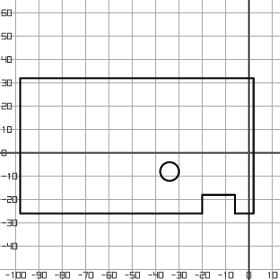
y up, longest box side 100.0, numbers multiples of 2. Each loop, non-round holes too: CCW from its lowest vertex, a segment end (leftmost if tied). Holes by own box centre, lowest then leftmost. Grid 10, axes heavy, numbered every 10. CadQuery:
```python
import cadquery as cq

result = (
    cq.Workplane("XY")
    .moveTo(-98.0, -26.0)
    .lineTo(-20.0, -26.0)
    .lineTo(-20.0, -18.0)
    .lineTo(-6.0, -18.0)
    .lineTo(-6.0, -26.0)
    .lineTo(2.0, -26.0)
    .lineTo(2.0, 32.0)
    .lineTo(-98.0, 32.0)
    .close()
    .moveTo(-34.0, -8.0)
    .circle(4.0)
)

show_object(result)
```